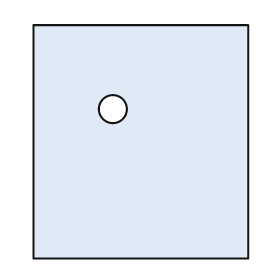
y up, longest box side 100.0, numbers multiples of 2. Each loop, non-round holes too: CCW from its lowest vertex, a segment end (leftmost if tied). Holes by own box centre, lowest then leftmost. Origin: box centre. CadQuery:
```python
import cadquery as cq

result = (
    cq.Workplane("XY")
    .moveTo(-46.0, -50.0)
    .lineTo(46.0, -50.0)
    .lineTo(46.0, 50.0)
    .lineTo(-46.0, 50.0)
    .close()
    .moveTo(-12.0, 14.0)
    .circle(6.0)
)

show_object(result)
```